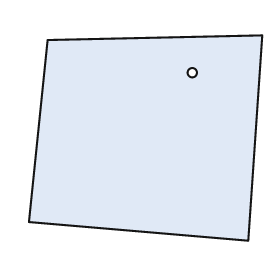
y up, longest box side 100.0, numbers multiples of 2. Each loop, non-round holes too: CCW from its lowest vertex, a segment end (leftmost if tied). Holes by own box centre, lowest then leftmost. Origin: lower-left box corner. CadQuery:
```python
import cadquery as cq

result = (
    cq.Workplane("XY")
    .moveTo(94.0, 0.0)
    .lineTo(100.0, 88.0)
    .lineTo(8.0, 86.0)
    .lineTo(0.0, 8.0)
    .close()
    .moveTo(70.0, 72.0)
    .circle(2.0)
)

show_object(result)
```